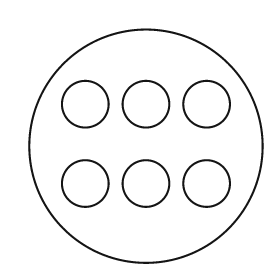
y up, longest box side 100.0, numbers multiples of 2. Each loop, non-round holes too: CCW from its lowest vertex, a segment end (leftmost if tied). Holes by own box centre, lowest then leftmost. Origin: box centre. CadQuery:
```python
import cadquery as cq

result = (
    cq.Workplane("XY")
    .moveTo(0.0, 0.0)
    .circle(50.0)
    .moveTo(-26.0, -16.0)
    .circle(10.0)
    .moveTo(0.0, -16.0)
    .circle(10.0)
    .moveTo(26.0, -16.0)
    .circle(10.0)
    .moveTo(-26.0, 18.0)
    .circle(10.0)
    .moveTo(0.0, 18.0)
    .circle(10.0)
    .moveTo(26.0, 18.0)
    .circle(10.0)
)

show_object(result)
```